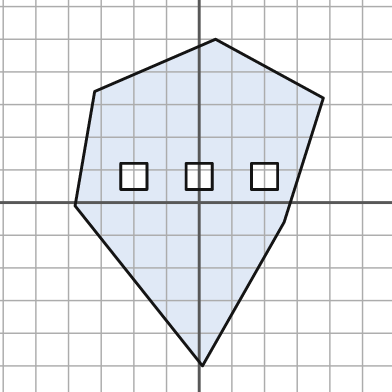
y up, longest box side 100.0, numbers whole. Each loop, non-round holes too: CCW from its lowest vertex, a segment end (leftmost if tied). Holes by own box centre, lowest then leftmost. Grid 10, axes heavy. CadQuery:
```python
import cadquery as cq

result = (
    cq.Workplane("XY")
    .moveTo(1.0, -50.0)
    .lineTo(26.0, -6.0)
    .lineTo(38.0, 32.0)
    .lineTo(5.0, 50.0)
    .lineTo(-32.0, 34.0)
    .lineTo(-38.0, -1.0)
    .close()
    .moveTo(-24.0, 4.0)
    .lineTo(-16.0, 4.0)
    .lineTo(-16.0, 12.0)
    .lineTo(-24.0, 12.0)
    .close()
    .moveTo(-4.0, 4.0)
    .lineTo(4.0, 4.0)
    .lineTo(4.0, 12.0)
    .lineTo(-4.0, 12.0)
    .close()
    .moveTo(16.0, 4.0)
    .lineTo(24.0, 4.0)
    .lineTo(24.0, 12.0)
    .lineTo(16.0, 12.0)
    .close()
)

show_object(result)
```